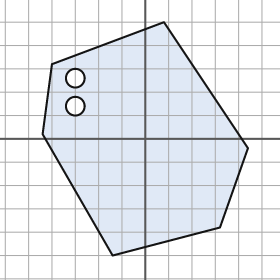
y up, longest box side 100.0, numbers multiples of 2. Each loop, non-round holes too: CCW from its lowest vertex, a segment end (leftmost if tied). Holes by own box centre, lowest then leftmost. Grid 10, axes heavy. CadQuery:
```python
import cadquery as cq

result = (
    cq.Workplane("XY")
    .moveTo(-14.0, -50.0)
    .lineTo(32.0, -38.0)
    .lineTo(44.0, -4.0)
    .lineTo(8.0, 50.0)
    .lineTo(-40.0, 32.0)
    .lineTo(-44.0, 2.0)
    .close()
    .moveTo(-30.0, 14.0)
    .circle(4.0)
    .moveTo(-30.0, 26.0)
    .circle(4.0)
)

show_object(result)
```